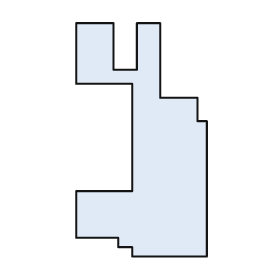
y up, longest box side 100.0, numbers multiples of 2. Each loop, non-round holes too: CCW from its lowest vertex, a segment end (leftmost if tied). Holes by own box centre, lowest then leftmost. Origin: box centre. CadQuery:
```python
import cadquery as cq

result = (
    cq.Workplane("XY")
    .moveTo(-4.0, -50.0)
    .lineTo(28.0, -50.0)
    .lineTo(28.0, 8.0)
    .lineTo(24.0, 8.0)
    .lineTo(24.0, 18.0)
    .lineTo(8.0, 18.0)
    .lineTo(8.0, 50.0)
    .lineTo(-2.0, 50.0)
    .lineTo(-2.0, 30.0)
    .lineTo(-12.0, 30.0)
    .lineTo(-12.0, 50.0)
    .lineTo(-28.0, 50.0)
    .lineTo(-28.0, 24.0)
    .lineTo(-4.0, 24.0)
    .lineTo(-4.0, -22.0)
    .lineTo(-28.0, -22.0)
    .lineTo(-28.0, -42.0)
    .lineTo(-10.0, -42.0)
    .lineTo(-10.0, -46.0)
    .lineTo(-4.0, -46.0)
    .close()
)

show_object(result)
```